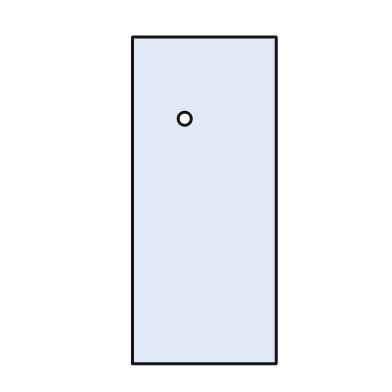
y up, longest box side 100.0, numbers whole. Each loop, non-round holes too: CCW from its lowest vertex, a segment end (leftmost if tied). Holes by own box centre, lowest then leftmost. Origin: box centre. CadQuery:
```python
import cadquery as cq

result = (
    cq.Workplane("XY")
    .moveTo(-22.0, -50.0)
    .lineTo(22.0, -50.0)
    .lineTo(22.0, 50.0)
    .lineTo(-22.0, 50.0)
    .close()
    .moveTo(-6.0, 25.0)
    .circle(2.0)
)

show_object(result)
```